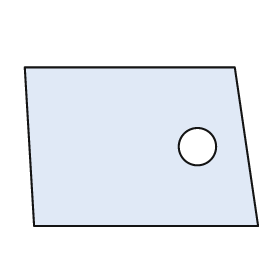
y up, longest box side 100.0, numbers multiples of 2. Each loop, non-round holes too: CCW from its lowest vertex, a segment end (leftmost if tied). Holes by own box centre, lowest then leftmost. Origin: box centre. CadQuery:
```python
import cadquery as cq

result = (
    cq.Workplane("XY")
    .moveTo(-46.0, -34.0)
    .lineTo(50.0, -34.0)
    .lineTo(40.0, 34.0)
    .lineTo(-50.0, 34.0)
    .close()
    .moveTo(24.0, 0.0)
    .circle(8.0)
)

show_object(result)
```